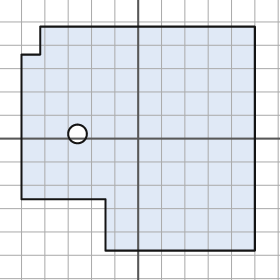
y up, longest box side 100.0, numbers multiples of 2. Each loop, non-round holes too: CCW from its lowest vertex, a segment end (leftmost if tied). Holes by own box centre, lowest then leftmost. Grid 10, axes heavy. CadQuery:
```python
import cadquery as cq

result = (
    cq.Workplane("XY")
    .moveTo(-14.0, -48.0)
    .lineTo(50.0, -48.0)
    .lineTo(50.0, 48.0)
    .lineTo(-42.0, 48.0)
    .lineTo(-42.0, 36.0)
    .lineTo(-50.0, 36.0)
    .lineTo(-50.0, -26.0)
    .lineTo(-14.0, -26.0)
    .close()
    .moveTo(-26.0, 2.0)
    .circle(4.0)
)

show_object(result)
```